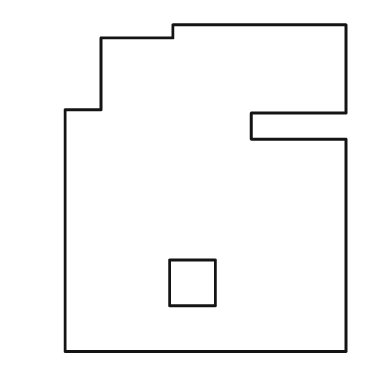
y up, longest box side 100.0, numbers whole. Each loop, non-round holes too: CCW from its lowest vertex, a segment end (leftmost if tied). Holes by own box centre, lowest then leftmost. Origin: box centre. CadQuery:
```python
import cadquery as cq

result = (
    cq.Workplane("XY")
    .moveTo(-43.0, -50.0)
    .lineTo(43.0, -50.0)
    .lineTo(43.0, 15.0)
    .lineTo(14.0, 15.0)
    .lineTo(14.0, 23.0)
    .lineTo(43.0, 23.0)
    .lineTo(43.0, 50.0)
    .lineTo(-10.0, 50.0)
    .lineTo(-10.0, 46.0)
    .lineTo(-32.0, 46.0)
    .lineTo(-32.0, 24.0)
    .lineTo(-43.0, 24.0)
    .close()
    .moveTo(-11.0, -36.0)
    .lineTo(3.0, -36.0)
    .lineTo(3.0, -22.0)
    .lineTo(-11.0, -22.0)
    .close()
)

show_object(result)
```